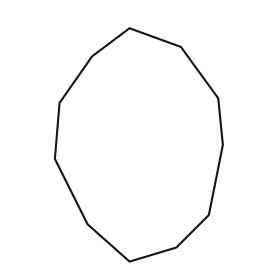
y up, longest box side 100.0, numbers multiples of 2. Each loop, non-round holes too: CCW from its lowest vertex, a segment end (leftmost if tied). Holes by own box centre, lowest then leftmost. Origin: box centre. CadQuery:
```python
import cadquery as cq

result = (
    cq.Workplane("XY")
    .moveTo(-4.0, -50.0)
    .lineTo(16.0, -44.0)
    .lineTo(30.0, -30.0)
    .lineTo(36.0, 0.0)
    .lineTo(34.0, 20.0)
    .lineTo(18.0, 42.0)
    .lineTo(-4.0, 50.0)
    .lineTo(-20.0, 38.0)
    .lineTo(-34.0, 18.0)
    .lineTo(-36.0, -6.0)
    .lineTo(-22.0, -34.0)
    .close()
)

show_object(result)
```